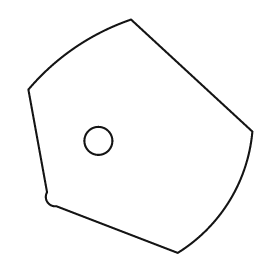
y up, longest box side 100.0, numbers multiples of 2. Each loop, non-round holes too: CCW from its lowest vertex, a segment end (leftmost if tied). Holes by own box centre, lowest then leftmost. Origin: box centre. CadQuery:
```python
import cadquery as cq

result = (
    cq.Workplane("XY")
    .moveTo(16.0, -50.0)
    .threePointArc((38.0, -28.0), (48.0, 2.0))
    .lineTo(-4.0, 50.0)
    .threePointArc((-28.0, 38.0), (-48.0, 20.0))
    .lineTo(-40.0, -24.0)
    .threePointArc((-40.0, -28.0), (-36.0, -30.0))
    .close()
    .moveTo(-18.0, -2.0)
    .circle(6.0)
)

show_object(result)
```